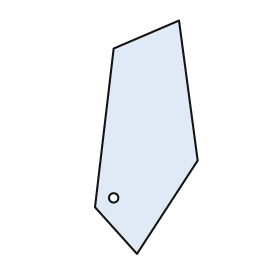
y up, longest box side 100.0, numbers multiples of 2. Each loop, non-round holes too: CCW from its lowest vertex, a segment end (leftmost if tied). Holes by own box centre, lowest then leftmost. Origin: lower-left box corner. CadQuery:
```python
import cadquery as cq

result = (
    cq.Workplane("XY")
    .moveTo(18.0, 0.0)
    .lineTo(44.0, 40.0)
    .lineTo(36.0, 100.0)
    .lineTo(8.0, 88.0)
    .lineTo(0.0, 20.0)
    .close()
    .moveTo(8.0, 24.0)
    .circle(2.0)
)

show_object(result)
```